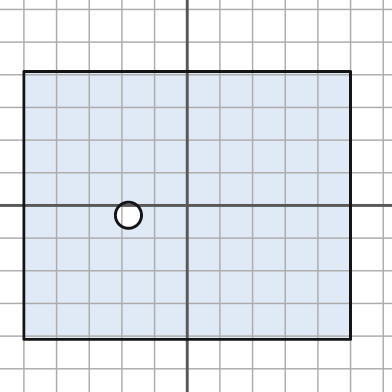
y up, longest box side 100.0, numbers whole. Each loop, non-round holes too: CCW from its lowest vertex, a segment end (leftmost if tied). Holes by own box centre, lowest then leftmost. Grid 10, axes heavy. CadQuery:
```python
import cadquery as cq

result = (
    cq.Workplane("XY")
    .moveTo(-50.0, -41.0)
    .lineTo(50.0, -41.0)
    .lineTo(50.0, 41.0)
    .lineTo(-50.0, 41.0)
    .close()
    .moveTo(-18.0, -3.0)
    .circle(4.0)
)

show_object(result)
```